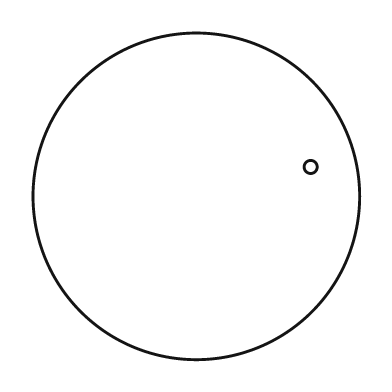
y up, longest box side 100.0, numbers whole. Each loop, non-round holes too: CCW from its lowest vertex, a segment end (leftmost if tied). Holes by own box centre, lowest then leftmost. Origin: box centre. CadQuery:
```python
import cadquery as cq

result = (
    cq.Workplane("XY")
    .moveTo(0.0, 0.0)
    .circle(50.0)
    .moveTo(35.0, 9.0)
    .circle(2.0)
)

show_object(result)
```